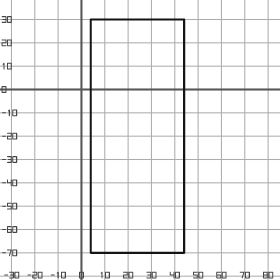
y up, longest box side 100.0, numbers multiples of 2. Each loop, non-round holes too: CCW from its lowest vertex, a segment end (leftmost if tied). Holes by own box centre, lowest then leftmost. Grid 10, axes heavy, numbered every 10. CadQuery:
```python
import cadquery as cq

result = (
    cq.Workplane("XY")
    .moveTo(4.0, -70.0)
    .lineTo(44.0, -70.0)
    .lineTo(44.0, 30.0)
    .lineTo(4.0, 30.0)
    .close()
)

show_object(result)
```